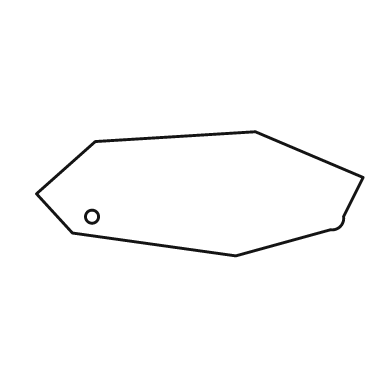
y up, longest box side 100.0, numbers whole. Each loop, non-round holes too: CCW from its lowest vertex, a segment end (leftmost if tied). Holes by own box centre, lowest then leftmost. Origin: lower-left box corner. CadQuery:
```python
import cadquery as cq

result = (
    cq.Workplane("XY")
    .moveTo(61.0, 0.0)
    .lineTo(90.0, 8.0)
    .threePointArc((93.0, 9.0), (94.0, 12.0))
    .lineTo(100.0, 24.0)
    .lineTo(67.0, 38.0)
    .lineTo(18.0, 35.0)
    .lineTo(0.0, 19.0)
    .lineTo(11.0, 7.0)
    .close()
    .moveTo(17.0, 12.0)
    .circle(2.0)
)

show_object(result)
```